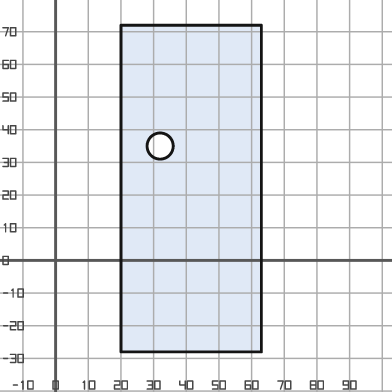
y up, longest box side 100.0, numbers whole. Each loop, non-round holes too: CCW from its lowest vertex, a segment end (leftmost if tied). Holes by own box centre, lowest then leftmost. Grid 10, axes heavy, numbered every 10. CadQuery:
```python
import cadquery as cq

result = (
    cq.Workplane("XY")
    .moveTo(20.0, -28.0)
    .lineTo(63.0, -28.0)
    .lineTo(63.0, 72.0)
    .lineTo(20.0, 72.0)
    .close()
    .moveTo(32.0, 35.0)
    .circle(4.0)
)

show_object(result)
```